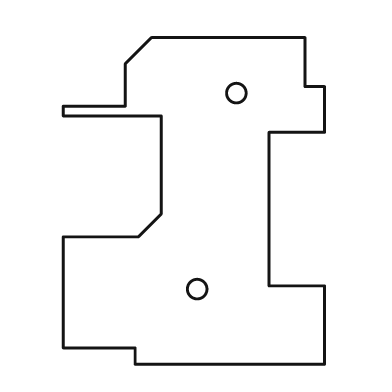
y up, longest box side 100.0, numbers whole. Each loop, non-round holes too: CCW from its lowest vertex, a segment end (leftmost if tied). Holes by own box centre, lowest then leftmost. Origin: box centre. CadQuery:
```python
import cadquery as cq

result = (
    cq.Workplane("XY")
    .moveTo(-18.0, -50.0)
    .lineTo(40.0, -50.0)
    .lineTo(40.0, -26.0)
    .lineTo(23.0, -26.0)
    .lineTo(23.0, 21.0)
    .lineTo(40.0, 21.0)
    .lineTo(40.0, 35.0)
    .lineTo(34.0, 35.0)
    .lineTo(34.0, 50.0)
    .lineTo(-13.0, 50.0)
    .lineTo(-21.0, 42.0)
    .lineTo(-21.0, 29.0)
    .lineTo(-40.0, 29.0)
    .lineTo(-40.0, 26.0)
    .lineTo(-10.0, 26.0)
    .lineTo(-10.0, -4.0)
    .lineTo(-17.0, -11.0)
    .lineTo(-40.0, -11.0)
    .lineTo(-40.0, -45.0)
    .lineTo(-18.0, -45.0)
    .close()
    .moveTo(1.0, -27.0)
    .circle(3.0)
    .moveTo(13.0, 33.0)
    .circle(3.0)
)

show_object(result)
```